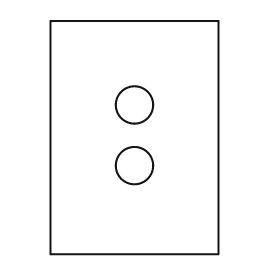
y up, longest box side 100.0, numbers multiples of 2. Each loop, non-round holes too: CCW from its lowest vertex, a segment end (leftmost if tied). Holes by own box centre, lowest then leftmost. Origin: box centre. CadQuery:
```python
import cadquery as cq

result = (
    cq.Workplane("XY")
    .moveTo(-36.0, -50.0)
    .lineTo(36.0, -50.0)
    .lineTo(36.0, 50.0)
    .lineTo(-36.0, 50.0)
    .close()
    .moveTo(0.0, -12.0)
    .circle(8.0)
    .moveTo(0.0, 14.0)
    .circle(8.0)
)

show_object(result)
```